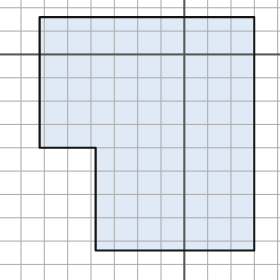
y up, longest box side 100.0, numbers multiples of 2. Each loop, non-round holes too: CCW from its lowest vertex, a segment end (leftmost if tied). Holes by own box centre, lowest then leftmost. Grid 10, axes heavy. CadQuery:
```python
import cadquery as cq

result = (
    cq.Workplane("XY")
    .moveTo(-38.0, -84.0)
    .lineTo(30.0, -84.0)
    .lineTo(30.0, 16.0)
    .lineTo(-62.0, 16.0)
    .lineTo(-62.0, -40.0)
    .lineTo(-38.0, -40.0)
    .close()
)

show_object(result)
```